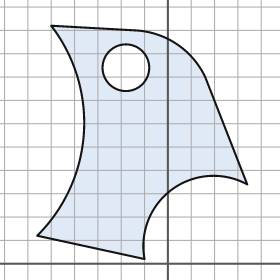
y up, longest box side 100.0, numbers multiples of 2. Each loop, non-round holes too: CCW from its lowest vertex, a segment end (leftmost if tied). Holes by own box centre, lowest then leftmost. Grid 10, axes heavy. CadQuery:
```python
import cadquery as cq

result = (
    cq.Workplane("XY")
    .moveTo(-10.0, 2.0)
    .threePointArc((2.0, 32.0), (34.0, 34.0))
    .lineTo(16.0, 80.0)
    .threePointArc((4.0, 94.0), (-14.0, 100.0))
    .lineTo(-50.0, 102.0)
    .threePointArc((-36.0, 56.0), (-56.0, 12.0))
    .close()
    .moveTo(-18.0, 84.0)
    .circle(10.0)
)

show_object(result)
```